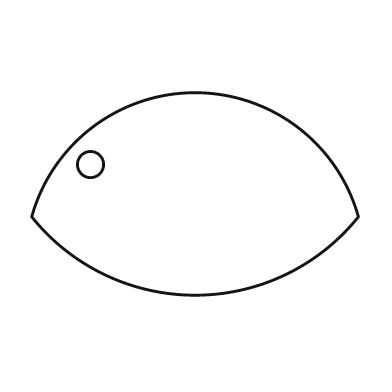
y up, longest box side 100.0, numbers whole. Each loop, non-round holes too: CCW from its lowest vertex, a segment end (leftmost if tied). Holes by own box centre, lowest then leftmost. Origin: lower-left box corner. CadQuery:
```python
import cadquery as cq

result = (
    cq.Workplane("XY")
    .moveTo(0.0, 24.0)
    .threePointArc((50.0, 0.0), (100.0, 24.0))
    .threePointArc((50.0, 62.0), (0.0, 24.0))
    .close()
    .moveTo(18.0, 40.0)
    .circle(4.0)
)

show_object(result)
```